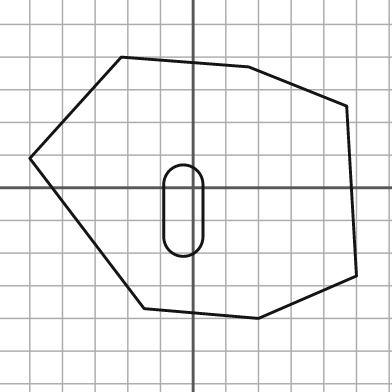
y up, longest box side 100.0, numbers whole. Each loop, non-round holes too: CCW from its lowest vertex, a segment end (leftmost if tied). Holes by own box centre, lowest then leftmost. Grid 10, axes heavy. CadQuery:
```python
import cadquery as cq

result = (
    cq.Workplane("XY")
    .moveTo(20.0, -40.0)
    .lineTo(50.0, -27.0)
    .lineTo(47.0, 25.0)
    .lineTo(17.0, 37.0)
    .lineTo(-22.0, 40.0)
    .lineTo(-50.0, 9.0)
    .lineTo(-15.0, -37.0)
    .close()
    .moveTo(-9.0, -15.0)
    .threePointArc((-3.0, -21.0), (3.0, -15.0))
    .lineTo(3.0, 1.0)
    .threePointArc((-3.0, 7.0), (-9.0, 1.0))
    .close()
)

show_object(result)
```